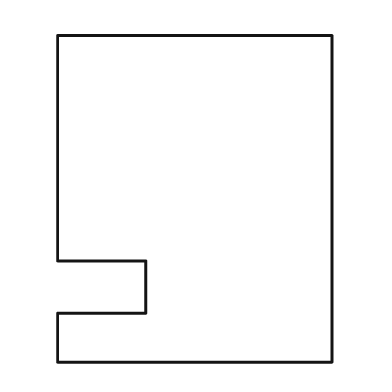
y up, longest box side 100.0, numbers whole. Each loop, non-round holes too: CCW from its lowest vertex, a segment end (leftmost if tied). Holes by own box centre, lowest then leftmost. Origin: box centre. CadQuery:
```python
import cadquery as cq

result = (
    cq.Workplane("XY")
    .moveTo(-42.0, -50.0)
    .lineTo(42.0, -50.0)
    .lineTo(42.0, 50.0)
    .lineTo(-42.0, 50.0)
    .lineTo(-42.0, -19.0)
    .lineTo(-15.0, -19.0)
    .lineTo(-15.0, -35.0)
    .lineTo(-42.0, -35.0)
    .close()
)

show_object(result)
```